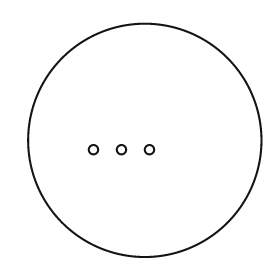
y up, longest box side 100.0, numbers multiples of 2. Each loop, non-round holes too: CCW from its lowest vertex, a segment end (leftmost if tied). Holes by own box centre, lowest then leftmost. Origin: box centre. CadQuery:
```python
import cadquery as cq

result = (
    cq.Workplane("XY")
    .moveTo(0.0, 0.0)
    .circle(50.0)
    .moveTo(-22.0, -4.0)
    .circle(2.0)
    .moveTo(-10.0, -4.0)
    .circle(2.0)
    .moveTo(2.0, -4.0)
    .circle(2.0)
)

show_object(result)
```